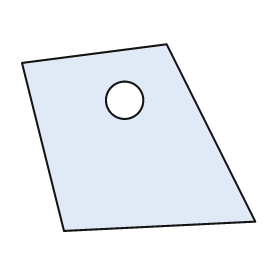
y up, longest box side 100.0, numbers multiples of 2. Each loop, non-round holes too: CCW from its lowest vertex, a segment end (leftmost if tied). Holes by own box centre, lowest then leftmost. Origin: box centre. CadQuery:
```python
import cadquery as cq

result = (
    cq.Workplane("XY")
    .moveTo(-32.0, -40.0)
    .lineTo(50.0, -36.0)
    .lineTo(12.0, 40.0)
    .lineTo(-50.0, 32.0)
    .close()
    .moveTo(-6.0, 16.0)
    .circle(8.0)
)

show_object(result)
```